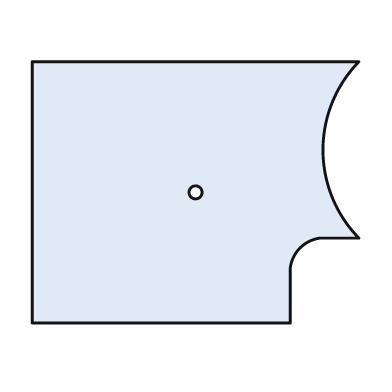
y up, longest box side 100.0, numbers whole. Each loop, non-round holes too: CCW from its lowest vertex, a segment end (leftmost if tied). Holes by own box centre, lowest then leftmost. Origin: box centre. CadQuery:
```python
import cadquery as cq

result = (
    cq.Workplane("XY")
    .moveTo(-50.0, -40.0)
    .lineTo(29.0, -40.0)
    .lineTo(29.0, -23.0)
    .threePointArc((32.0, -17.0), (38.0, -14.0))
    .lineTo(50.0, -14.0)
    .threePointArc((39.0, 13.0), (50.0, 40.0))
    .lineTo(-50.0, 40.0)
    .close()
    .moveTo(0.0, 0.0)
    .circle(2.0)
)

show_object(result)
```